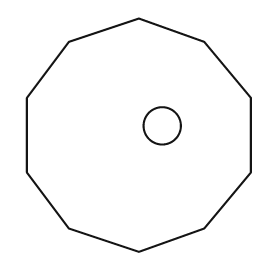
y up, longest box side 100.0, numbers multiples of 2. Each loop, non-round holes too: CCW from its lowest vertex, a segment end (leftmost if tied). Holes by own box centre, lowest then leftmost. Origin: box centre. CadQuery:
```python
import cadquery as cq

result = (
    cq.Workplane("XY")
    .moveTo(0.0, -50.0)
    .lineTo(28.0, -40.0)
    .lineTo(48.0, -16.0)
    .lineTo(48.0, 16.0)
    .lineTo(28.0, 40.0)
    .lineTo(0.0, 50.0)
    .lineTo(-30.0, 40.0)
    .lineTo(-48.0, 16.0)
    .lineTo(-48.0, -16.0)
    .lineTo(-30.0, -40.0)
    .close()
    .moveTo(10.0, 4.0)
    .circle(8.0)
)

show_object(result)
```